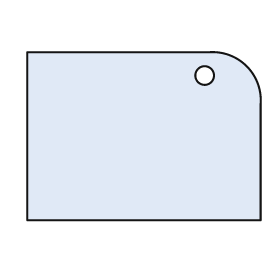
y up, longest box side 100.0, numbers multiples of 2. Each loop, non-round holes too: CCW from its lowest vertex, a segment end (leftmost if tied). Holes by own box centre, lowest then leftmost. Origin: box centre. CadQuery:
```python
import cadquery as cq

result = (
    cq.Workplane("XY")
    .moveTo(-50.0, -36.0)
    .lineTo(50.0, -36.0)
    .lineTo(50.0, 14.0)
    .threePointArc((44.0, 30.0), (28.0, 36.0))
    .lineTo(-50.0, 36.0)
    .close()
    .moveTo(26.0, 26.0)
    .circle(4.0)
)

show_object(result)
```